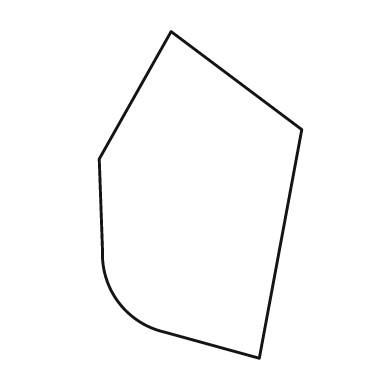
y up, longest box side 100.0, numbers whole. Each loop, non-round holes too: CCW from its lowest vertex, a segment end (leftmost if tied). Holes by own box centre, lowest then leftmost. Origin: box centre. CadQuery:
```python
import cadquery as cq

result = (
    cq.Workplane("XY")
    .moveTo(18.0, -50.0)
    .lineTo(31.0, 20.0)
    .lineTo(-9.0, 50.0)
    .lineTo(-31.0, 11.0)
    .lineTo(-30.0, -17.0)
    .threePointArc((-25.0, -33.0), (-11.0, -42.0))
    .close()
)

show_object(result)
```